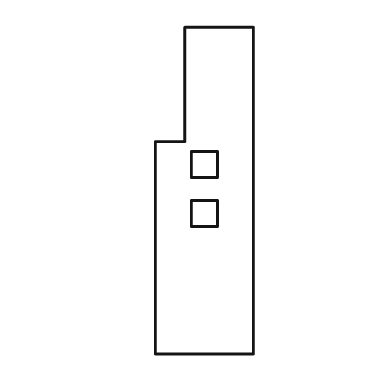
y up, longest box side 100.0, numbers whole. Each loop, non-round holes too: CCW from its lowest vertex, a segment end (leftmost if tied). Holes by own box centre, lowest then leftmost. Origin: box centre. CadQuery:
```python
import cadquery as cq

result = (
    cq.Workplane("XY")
    .moveTo(-15.0, -50.0)
    .lineTo(15.0, -50.0)
    .lineTo(15.0, 50.0)
    .lineTo(-6.0, 50.0)
    .lineTo(-6.0, 15.0)
    .lineTo(-15.0, 15.0)
    .close()
    .moveTo(-4.0, -11.0)
    .lineTo(4.0, -11.0)
    .lineTo(4.0, -3.0)
    .lineTo(-4.0, -3.0)
    .close()
    .moveTo(-4.0, 4.0)
    .lineTo(4.0, 4.0)
    .lineTo(4.0, 12.0)
    .lineTo(-4.0, 12.0)
    .close()
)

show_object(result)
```